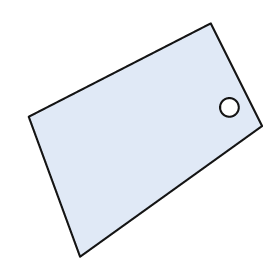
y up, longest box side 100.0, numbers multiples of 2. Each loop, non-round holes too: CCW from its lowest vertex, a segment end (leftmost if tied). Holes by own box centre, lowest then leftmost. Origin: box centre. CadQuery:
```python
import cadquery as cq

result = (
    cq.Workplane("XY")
    .moveTo(-28.0, -50.0)
    .lineTo(50.0, 6.0)
    .lineTo(28.0, 50.0)
    .lineTo(-50.0, 10.0)
    .close()
    .moveTo(36.0, 14.0)
    .circle(4.0)
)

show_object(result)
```